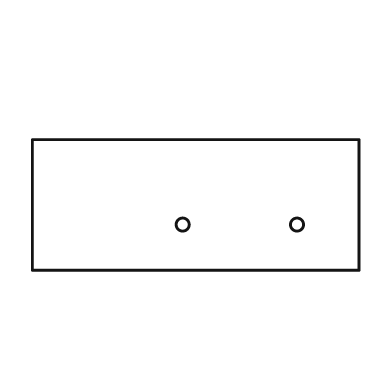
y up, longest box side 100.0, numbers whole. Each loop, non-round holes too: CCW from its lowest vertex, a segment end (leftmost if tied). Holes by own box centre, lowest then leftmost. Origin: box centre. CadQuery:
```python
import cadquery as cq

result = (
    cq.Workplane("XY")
    .moveTo(-50.0, -20.0)
    .lineTo(50.0, -20.0)
    .lineTo(50.0, 20.0)
    .lineTo(-50.0, 20.0)
    .close()
    .moveTo(-4.0, -6.0)
    .circle(2.0)
    .moveTo(31.0, -6.0)
    .circle(2.0)
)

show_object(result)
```